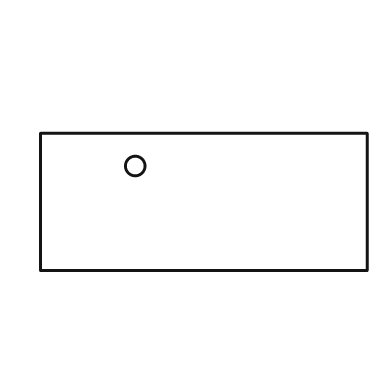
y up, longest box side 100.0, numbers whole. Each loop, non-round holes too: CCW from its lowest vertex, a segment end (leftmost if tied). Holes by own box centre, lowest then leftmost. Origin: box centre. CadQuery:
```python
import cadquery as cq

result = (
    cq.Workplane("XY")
    .moveTo(-50.0, -21.0)
    .lineTo(50.0, -21.0)
    .lineTo(50.0, 21.0)
    .lineTo(-50.0, 21.0)
    .close()
    .moveTo(-21.0, 11.0)
    .circle(3.0)
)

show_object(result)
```